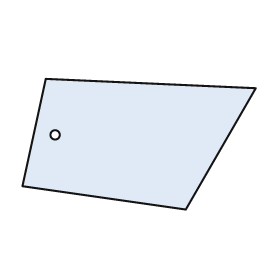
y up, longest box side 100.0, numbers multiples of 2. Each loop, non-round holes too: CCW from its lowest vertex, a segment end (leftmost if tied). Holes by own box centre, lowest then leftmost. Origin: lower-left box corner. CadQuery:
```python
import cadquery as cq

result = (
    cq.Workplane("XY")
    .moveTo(70.0, 0.0)
    .lineTo(100.0, 52.0)
    .lineTo(10.0, 56.0)
    .lineTo(0.0, 10.0)
    .close()
    .moveTo(14.0, 32.0)
    .circle(2.0)
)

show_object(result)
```